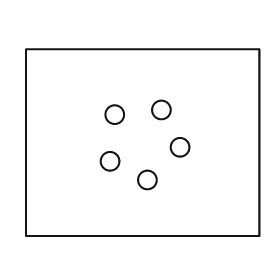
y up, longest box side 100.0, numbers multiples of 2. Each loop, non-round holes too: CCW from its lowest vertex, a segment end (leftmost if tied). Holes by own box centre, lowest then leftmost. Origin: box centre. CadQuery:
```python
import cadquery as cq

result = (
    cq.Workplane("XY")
    .moveTo(-50.0, -40.0)
    .lineTo(50.0, -40.0)
    .lineTo(50.0, 40.0)
    .lineTo(-50.0, 40.0)
    .close()
    .moveTo(2.0, -16.0)
    .circle(4.0)
    .moveTo(-14.0, -8.0)
    .circle(4.0)
    .moveTo(16.0, -2.0)
    .circle(4.0)
    .moveTo(-12.0, 12.0)
    .circle(4.0)
    .moveTo(8.0, 14.0)
    .circle(4.0)
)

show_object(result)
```